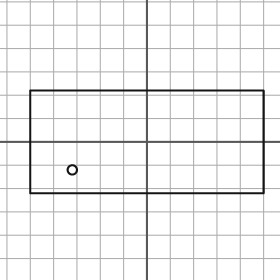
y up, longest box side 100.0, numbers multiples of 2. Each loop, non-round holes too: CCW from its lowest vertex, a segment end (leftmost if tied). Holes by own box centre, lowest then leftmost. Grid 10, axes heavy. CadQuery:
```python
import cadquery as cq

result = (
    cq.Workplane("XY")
    .moveTo(-50.0, -22.0)
    .lineTo(50.0, -22.0)
    .lineTo(50.0, 22.0)
    .lineTo(-50.0, 22.0)
    .close()
    .moveTo(-32.0, -12.0)
    .circle(2.0)
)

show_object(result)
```